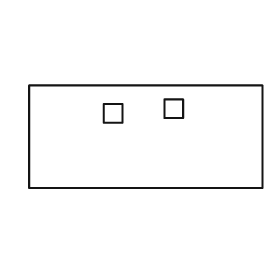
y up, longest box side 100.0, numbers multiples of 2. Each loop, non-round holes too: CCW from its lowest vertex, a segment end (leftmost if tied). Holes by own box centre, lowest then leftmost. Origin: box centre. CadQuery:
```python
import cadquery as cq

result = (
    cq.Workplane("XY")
    .moveTo(-50.0, -22.0)
    .lineTo(50.0, -22.0)
    .lineTo(50.0, 22.0)
    .lineTo(-50.0, 22.0)
    .close()
    .moveTo(-18.0, 6.0)
    .lineTo(-10.0, 6.0)
    .lineTo(-10.0, 14.0)
    .lineTo(-18.0, 14.0)
    .close()
    .moveTo(8.0, 8.0)
    .lineTo(16.0, 8.0)
    .lineTo(16.0, 16.0)
    .lineTo(8.0, 16.0)
    .close()
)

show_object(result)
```